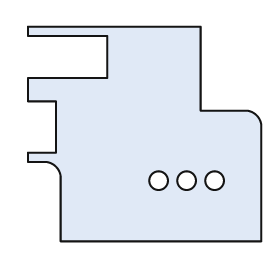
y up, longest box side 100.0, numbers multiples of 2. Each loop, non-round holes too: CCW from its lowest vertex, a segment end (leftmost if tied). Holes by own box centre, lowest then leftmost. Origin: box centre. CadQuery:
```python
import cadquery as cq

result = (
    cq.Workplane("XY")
    .moveTo(-36.0, -46.0)
    .lineTo(50.0, -46.0)
    .lineTo(50.0, 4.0)
    .threePointArc((48.0, 8.0), (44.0, 10.0))
    .lineTo(24.0, 10.0)
    .lineTo(24.0, 46.0)
    .lineTo(-50.0, 46.0)
    .lineTo(-50.0, 42.0)
    .lineTo(-16.0, 42.0)
    .lineTo(-16.0, 24.0)
    .lineTo(-50.0, 24.0)
    .lineTo(-50.0, 14.0)
    .lineTo(-38.0, 14.0)
    .lineTo(-38.0, -8.0)
    .lineTo(-50.0, -8.0)
    .lineTo(-50.0, -12.0)
    .lineTo(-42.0, -12.0)
    .threePointArc((-38.0, -14.0), (-36.0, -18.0))
    .close()
    .moveTo(6.0, -20.0)
    .circle(4.0)
    .moveTo(18.0, -20.0)
    .circle(4.0)
    .moveTo(30.0, -20.0)
    .circle(4.0)
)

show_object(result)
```